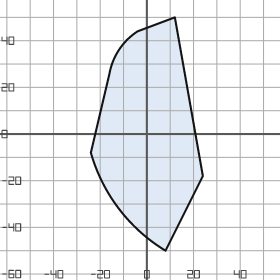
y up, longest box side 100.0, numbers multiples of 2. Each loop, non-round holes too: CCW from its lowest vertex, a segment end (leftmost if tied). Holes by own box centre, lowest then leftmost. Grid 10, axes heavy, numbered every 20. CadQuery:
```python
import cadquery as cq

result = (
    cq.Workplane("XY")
    .moveTo(8.0, -50.0)
    .lineTo(24.0, -18.0)
    .lineTo(12.0, 50.0)
    .lineTo(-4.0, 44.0)
    .threePointArc((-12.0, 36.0), (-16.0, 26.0))
    .lineTo(-24.0, -8.0)
    .threePointArc((-12.0, -32.0), (8.0, -50.0))
    .close()
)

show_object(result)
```